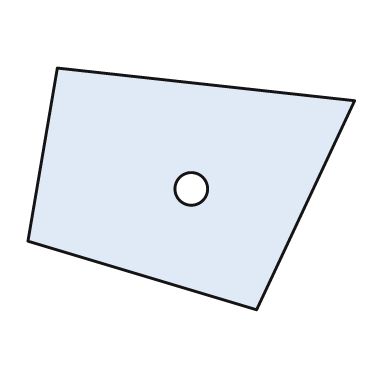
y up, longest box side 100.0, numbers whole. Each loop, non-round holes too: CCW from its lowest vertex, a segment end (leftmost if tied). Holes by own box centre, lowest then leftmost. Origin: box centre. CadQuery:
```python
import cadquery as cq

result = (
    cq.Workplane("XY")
    .moveTo(20.0, -37.0)
    .lineTo(50.0, 27.0)
    .lineTo(-41.0, 37.0)
    .lineTo(-50.0, -16.0)
    .close()
    .moveTo(0.0, 0.0)
    .circle(5.0)
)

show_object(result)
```